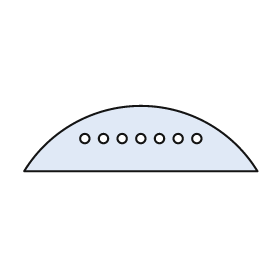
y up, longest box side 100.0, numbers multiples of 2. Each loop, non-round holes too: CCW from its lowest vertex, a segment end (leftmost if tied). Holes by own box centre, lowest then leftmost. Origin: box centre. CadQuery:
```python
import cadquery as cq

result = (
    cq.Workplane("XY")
    .moveTo(-50.0, -14.0)
    .lineTo(50.0, -14.0)
    .threePointArc((0.0, 14.0), (-50.0, -14.0))
    .close()
    .moveTo(-24.0, 0.0)
    .circle(2.0)
    .moveTo(-16.0, 0.0)
    .circle(2.0)
    .moveTo(-8.0, 0.0)
    .circle(2.0)
    .moveTo(0.0, 0.0)
    .circle(2.0)
    .moveTo(8.0, 0.0)
    .circle(2.0)
    .moveTo(16.0, 0.0)
    .circle(2.0)
    .moveTo(24.0, 0.0)
    .circle(2.0)
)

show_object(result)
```